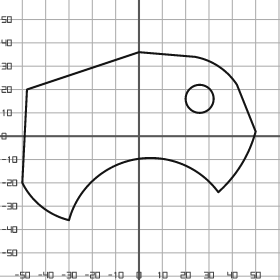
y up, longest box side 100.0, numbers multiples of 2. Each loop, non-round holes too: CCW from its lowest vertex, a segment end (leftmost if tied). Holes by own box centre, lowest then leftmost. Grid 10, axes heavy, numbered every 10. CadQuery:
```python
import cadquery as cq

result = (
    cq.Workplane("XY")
    .moveTo(-30.0, -36.0)
    .threePointArc((-2.0, -10.0), (34.0, -24.0))
    .threePointArc((44.0, -12.0), (50.0, 2.0))
    .lineTo(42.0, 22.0)
    .threePointArc((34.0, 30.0), (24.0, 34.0))
    .lineTo(0.0, 36.0)
    .lineTo(-48.0, 20.0)
    .lineTo(-50.0, -20.0)
    .threePointArc((-42.0, -30.0), (-30.0, -36.0))
    .close()
    .moveTo(26.0, 16.0)
    .circle(6.0)
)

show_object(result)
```